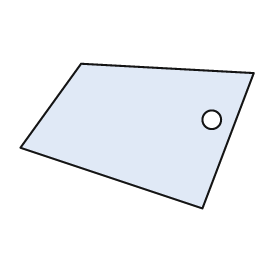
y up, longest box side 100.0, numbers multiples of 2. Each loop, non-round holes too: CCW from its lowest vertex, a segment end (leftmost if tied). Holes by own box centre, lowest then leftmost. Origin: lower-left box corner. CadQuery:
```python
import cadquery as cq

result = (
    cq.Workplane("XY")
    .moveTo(78.0, 0.0)
    .lineTo(100.0, 58.0)
    .lineTo(26.0, 62.0)
    .lineTo(0.0, 26.0)
    .close()
    .moveTo(82.0, 38.0)
    .circle(4.0)
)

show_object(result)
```